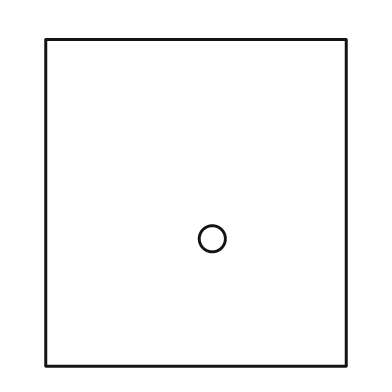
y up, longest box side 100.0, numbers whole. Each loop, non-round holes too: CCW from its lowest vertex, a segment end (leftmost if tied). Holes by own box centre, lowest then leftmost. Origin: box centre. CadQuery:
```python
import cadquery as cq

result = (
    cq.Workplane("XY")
    .moveTo(-46.0, -50.0)
    .lineTo(46.0, -50.0)
    .lineTo(46.0, 50.0)
    .lineTo(-46.0, 50.0)
    .close()
    .moveTo(5.0, -11.0)
    .circle(4.0)
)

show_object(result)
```